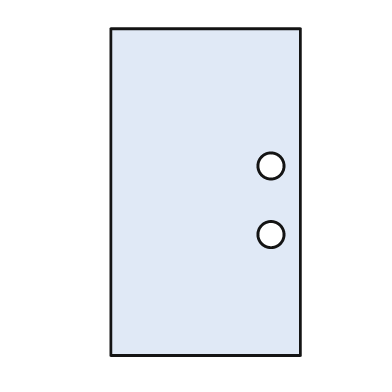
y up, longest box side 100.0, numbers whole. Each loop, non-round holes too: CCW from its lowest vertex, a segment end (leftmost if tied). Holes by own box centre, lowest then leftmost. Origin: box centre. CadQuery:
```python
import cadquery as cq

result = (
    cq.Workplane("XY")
    .moveTo(-29.0, -50.0)
    .lineTo(29.0, -50.0)
    .lineTo(29.0, 50.0)
    .lineTo(-29.0, 50.0)
    .close()
    .moveTo(20.0, -13.0)
    .circle(4.0)
    .moveTo(20.0, 8.0)
    .circle(4.0)
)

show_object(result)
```